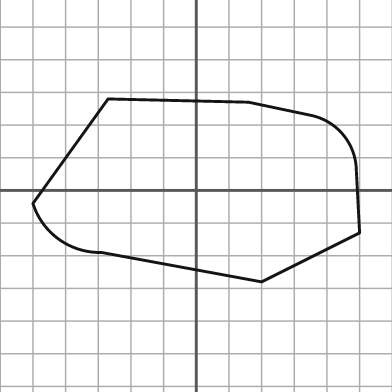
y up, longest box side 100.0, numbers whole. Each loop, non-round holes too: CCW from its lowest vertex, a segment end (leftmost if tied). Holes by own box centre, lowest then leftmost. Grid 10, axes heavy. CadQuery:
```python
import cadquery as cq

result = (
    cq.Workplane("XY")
    .moveTo(20.0, -28.0)
    .lineTo(50.0, -13.0)
    .lineTo(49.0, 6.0)
    .threePointArc((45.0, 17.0), (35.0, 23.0))
    .lineTo(16.0, 27.0)
    .lineTo(-27.0, 28.0)
    .lineTo(-50.0, -4.0)
    .threePointArc((-42.0, -15.0), (-29.0, -19.0))
    .close()
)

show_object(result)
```